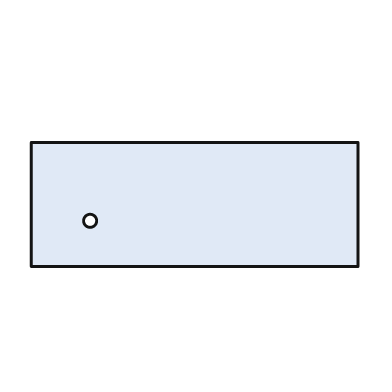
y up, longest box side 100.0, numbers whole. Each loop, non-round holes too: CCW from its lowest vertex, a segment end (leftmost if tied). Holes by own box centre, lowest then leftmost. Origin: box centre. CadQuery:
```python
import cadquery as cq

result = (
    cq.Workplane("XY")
    .moveTo(-50.0, -19.0)
    .lineTo(50.0, -19.0)
    .lineTo(50.0, 19.0)
    .lineTo(-50.0, 19.0)
    .close()
    .moveTo(-32.0, -5.0)
    .circle(2.0)
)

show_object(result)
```